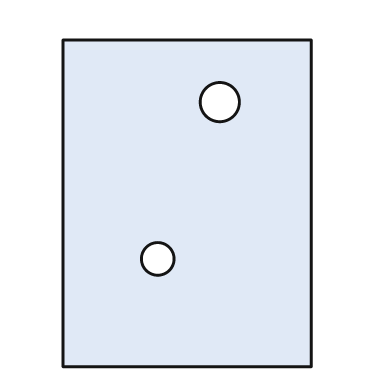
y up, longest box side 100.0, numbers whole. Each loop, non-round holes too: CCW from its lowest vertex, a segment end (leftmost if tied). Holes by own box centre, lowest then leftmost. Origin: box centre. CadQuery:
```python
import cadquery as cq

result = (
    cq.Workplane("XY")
    .moveTo(-38.0, -50.0)
    .lineTo(38.0, -50.0)
    .lineTo(38.0, 50.0)
    .lineTo(-38.0, 50.0)
    .close()
    .moveTo(-9.0, -17.0)
    .circle(5.0)
    .moveTo(10.0, 31.0)
    .circle(6.0)
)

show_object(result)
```